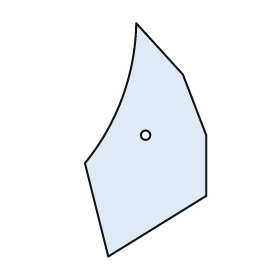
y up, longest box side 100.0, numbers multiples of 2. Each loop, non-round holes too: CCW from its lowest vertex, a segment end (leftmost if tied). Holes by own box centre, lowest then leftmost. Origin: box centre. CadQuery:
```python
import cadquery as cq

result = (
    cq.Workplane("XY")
    .moveTo(-16.0, -50.0)
    .lineTo(26.0, -24.0)
    .lineTo(26.0, 2.0)
    .lineTo(16.0, 28.0)
    .lineTo(-4.0, 50.0)
    .threePointArc((-10.0, 18.0), (-26.0, -10.0))
    .close()
    .moveTo(0.0, 2.0)
    .circle(2.0)
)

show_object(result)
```